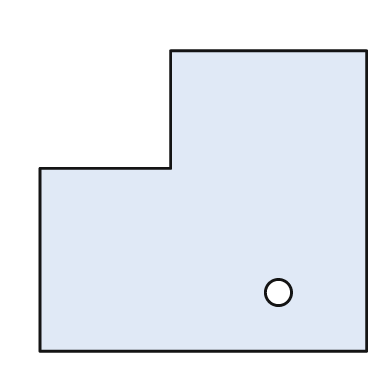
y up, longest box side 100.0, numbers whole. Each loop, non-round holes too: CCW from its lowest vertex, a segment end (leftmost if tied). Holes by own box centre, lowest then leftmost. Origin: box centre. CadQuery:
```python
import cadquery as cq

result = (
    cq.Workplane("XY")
    .moveTo(-50.0, -46.0)
    .lineTo(50.0, -46.0)
    .lineTo(50.0, 46.0)
    .lineTo(-10.0, 46.0)
    .lineTo(-10.0, 10.0)
    .lineTo(-50.0, 10.0)
    .close()
    .moveTo(23.0, -28.0)
    .circle(4.0)
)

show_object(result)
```